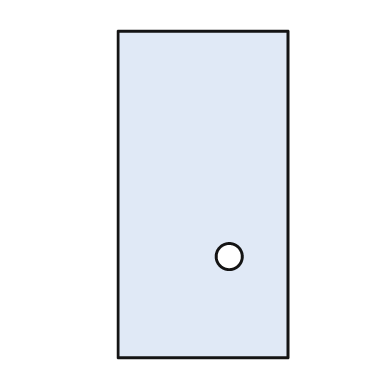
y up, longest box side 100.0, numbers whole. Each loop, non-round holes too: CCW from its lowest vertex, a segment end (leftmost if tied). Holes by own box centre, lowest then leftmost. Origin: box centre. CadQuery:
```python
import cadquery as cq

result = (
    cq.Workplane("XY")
    .moveTo(-26.0, -50.0)
    .lineTo(26.0, -50.0)
    .lineTo(26.0, 50.0)
    .lineTo(-26.0, 50.0)
    .close()
    .moveTo(8.0, -19.0)
    .circle(4.0)
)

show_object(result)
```